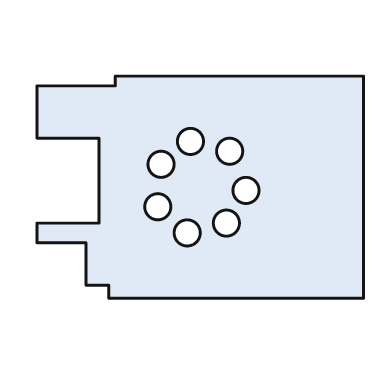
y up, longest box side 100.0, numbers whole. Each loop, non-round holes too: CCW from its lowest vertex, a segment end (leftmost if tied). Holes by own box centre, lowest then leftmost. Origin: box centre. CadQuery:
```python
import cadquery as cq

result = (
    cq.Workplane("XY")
    .moveTo(-28.0, -34.0)
    .lineTo(50.0, -34.0)
    .lineTo(50.0, 34.0)
    .lineTo(-26.0, 34.0)
    .lineTo(-26.0, 31.0)
    .lineTo(-50.0, 31.0)
    .lineTo(-50.0, 15.0)
    .lineTo(-31.0, 15.0)
    .lineTo(-31.0, -11.0)
    .lineTo(-50.0, -11.0)
    .lineTo(-50.0, -17.0)
    .lineTo(-35.0, -17.0)
    .lineTo(-35.0, -30.0)
    .lineTo(-28.0, -30.0)
    .close()
    .moveTo(-4.0, -14.0)
    .circle(4.0)
    .moveTo(8.0, -11.0)
    .circle(4.0)
    .moveTo(-13.0, -6.0)
    .circle(4.0)
    .moveTo(14.0, -1.0)
    .circle(4.0)
    .moveTo(-12.0, 7.0)
    .circle(4.0)
    .moveTo(9.0, 11.0)
    .circle(4.0)
    .moveTo(-3.0, 14.0)
    .circle(4.0)
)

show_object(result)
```